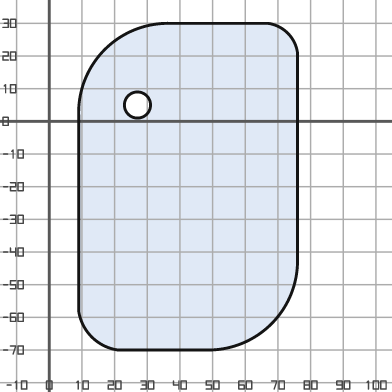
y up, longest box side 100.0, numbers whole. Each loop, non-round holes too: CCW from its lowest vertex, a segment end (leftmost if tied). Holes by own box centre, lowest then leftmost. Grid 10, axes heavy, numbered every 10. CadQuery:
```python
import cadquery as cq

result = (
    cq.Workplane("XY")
    .moveTo(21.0, -70.0)
    .lineTo(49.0, -70.0)
    .threePointArc((68.0, -62.0), (76.0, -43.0))
    .lineTo(76.0, 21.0)
    .threePointArc((73.0, 27.0), (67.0, 30.0))
    .lineTo(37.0, 30.0)
    .threePointArc((17.0, 22.0), (9.0, 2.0))
    .lineTo(9.0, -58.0)
    .threePointArc((13.0, -66.0), (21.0, -70.0))
    .close()
    .moveTo(27.0, 5.0)
    .circle(4.0)
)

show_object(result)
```